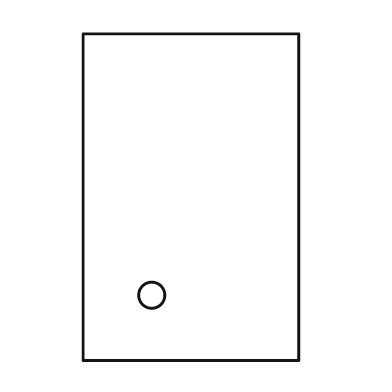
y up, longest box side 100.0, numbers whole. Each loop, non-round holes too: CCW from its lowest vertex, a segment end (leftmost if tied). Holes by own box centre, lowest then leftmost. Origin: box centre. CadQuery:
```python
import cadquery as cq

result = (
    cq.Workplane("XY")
    .moveTo(-33.0, -50.0)
    .lineTo(33.0, -50.0)
    .lineTo(33.0, 50.0)
    .lineTo(-33.0, 50.0)
    .close()
    .moveTo(-12.0, -30.0)
    .circle(4.0)
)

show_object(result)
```